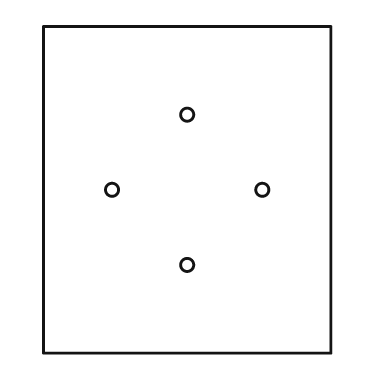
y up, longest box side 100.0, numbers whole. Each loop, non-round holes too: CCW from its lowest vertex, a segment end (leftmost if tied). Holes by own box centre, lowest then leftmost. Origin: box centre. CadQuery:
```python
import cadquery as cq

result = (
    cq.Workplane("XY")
    .moveTo(-44.0, -50.0)
    .lineTo(44.0, -50.0)
    .lineTo(44.0, 50.0)
    .lineTo(-44.0, 50.0)
    .close()
    .moveTo(0.0, -23.0)
    .circle(2.0)
    .moveTo(-23.0, 0.0)
    .circle(2.0)
    .moveTo(23.0, 0.0)
    .circle(2.0)
    .moveTo(0.0, 23.0)
    .circle(2.0)
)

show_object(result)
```